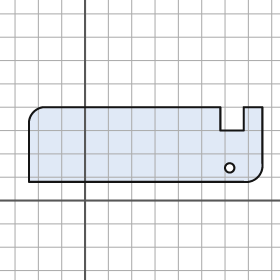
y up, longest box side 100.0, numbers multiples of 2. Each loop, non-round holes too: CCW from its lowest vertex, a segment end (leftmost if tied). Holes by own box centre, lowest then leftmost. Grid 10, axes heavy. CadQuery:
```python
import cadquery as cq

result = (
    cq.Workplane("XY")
    .moveTo(-24.0, 8.0)
    .lineTo(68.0, 8.0)
    .threePointArc((74.0, 10.0), (76.0, 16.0))
    .lineTo(76.0, 40.0)
    .lineTo(68.0, 40.0)
    .lineTo(68.0, 30.0)
    .lineTo(58.0, 30.0)
    .lineTo(58.0, 40.0)
    .lineTo(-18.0, 40.0)
    .threePointArc((-22.0, 38.0), (-24.0, 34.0))
    .close()
    .moveTo(62.0, 14.0)
    .circle(2.0)
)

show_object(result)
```